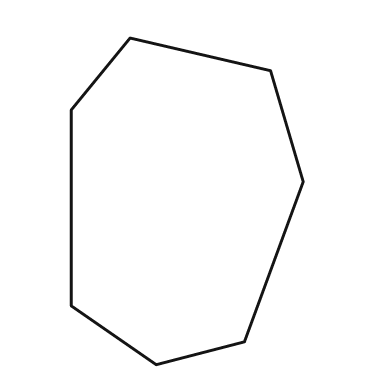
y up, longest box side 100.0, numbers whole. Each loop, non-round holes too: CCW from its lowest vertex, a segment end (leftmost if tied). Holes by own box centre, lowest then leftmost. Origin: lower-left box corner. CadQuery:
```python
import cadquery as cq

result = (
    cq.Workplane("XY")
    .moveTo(26.0, 0.0)
    .lineTo(53.0, 7.0)
    .lineTo(71.0, 56.0)
    .lineTo(61.0, 90.0)
    .lineTo(18.0, 100.0)
    .lineTo(0.0, 78.0)
    .lineTo(0.0, 18.0)
    .close()
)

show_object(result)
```